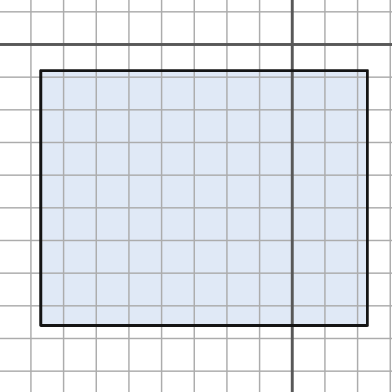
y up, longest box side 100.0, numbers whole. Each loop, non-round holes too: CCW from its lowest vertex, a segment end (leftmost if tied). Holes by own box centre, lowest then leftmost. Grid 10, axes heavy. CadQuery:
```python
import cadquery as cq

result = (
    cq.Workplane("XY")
    .moveTo(-77.0, -86.0)
    .lineTo(23.0, -86.0)
    .lineTo(23.0, -8.0)
    .lineTo(-77.0, -8.0)
    .close()
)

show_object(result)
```